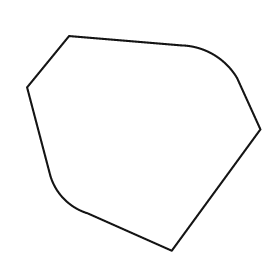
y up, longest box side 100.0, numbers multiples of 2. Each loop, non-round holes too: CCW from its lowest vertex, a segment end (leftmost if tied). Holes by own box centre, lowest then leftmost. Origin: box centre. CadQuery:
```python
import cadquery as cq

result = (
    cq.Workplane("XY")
    .moveTo(12.0, -46.0)
    .lineTo(50.0, 6.0)
    .lineTo(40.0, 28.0)
    .threePointArc((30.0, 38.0), (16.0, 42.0))
    .lineTo(-32.0, 46.0)
    .lineTo(-50.0, 24.0)
    .lineTo(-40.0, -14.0)
    .threePointArc((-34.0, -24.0), (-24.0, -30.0))
    .close()
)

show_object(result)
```